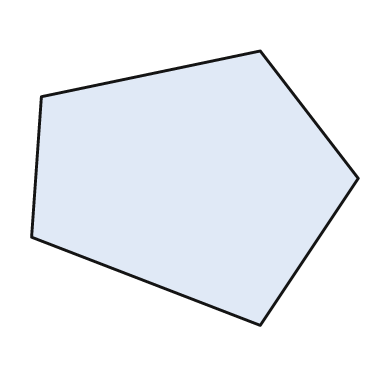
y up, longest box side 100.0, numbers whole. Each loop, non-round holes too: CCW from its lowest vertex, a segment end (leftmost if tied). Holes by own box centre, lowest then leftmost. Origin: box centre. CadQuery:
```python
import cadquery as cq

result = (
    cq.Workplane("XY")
    .moveTo(20.0, -42.0)
    .lineTo(50.0, 3.0)
    .lineTo(20.0, 42.0)
    .lineTo(-47.0, 28.0)
    .lineTo(-50.0, -15.0)
    .close()
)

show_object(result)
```